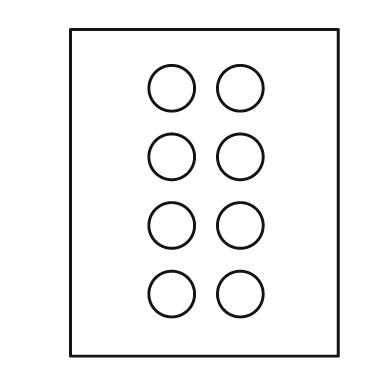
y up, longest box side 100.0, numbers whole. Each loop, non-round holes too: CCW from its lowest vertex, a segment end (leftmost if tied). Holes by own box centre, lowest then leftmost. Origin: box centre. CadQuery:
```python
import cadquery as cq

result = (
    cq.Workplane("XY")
    .moveTo(-41.0, -50.0)
    .lineTo(41.0, -50.0)
    .lineTo(41.0, 50.0)
    .lineTo(-41.0, 50.0)
    .close()
    .moveTo(-10.0, -31.0)
    .circle(7.0)
    .moveTo(11.0, -31.0)
    .circle(7.0)
    .moveTo(-10.0, -10.0)
    .circle(7.0)
    .moveTo(11.0, -10.0)
    .circle(7.0)
    .moveTo(-10.0, 11.0)
    .circle(7.0)
    .moveTo(11.0, 11.0)
    .circle(7.0)
    .moveTo(-10.0, 32.0)
    .circle(7.0)
    .moveTo(11.0, 32.0)
    .circle(7.0)
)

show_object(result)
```